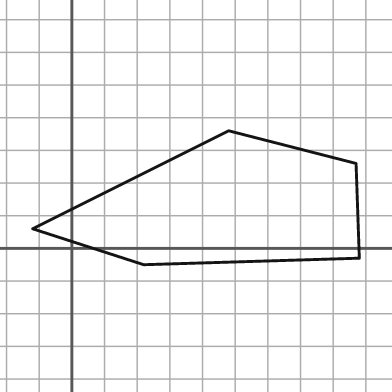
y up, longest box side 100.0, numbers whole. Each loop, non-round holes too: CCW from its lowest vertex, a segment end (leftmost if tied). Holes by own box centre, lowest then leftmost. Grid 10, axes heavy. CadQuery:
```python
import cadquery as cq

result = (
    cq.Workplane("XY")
    .moveTo(22.0, -5.0)
    .lineTo(88.0, -3.0)
    .lineTo(87.0, 26.0)
    .lineTo(48.0, 36.0)
    .lineTo(-12.0, 6.0)
    .close()
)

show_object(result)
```